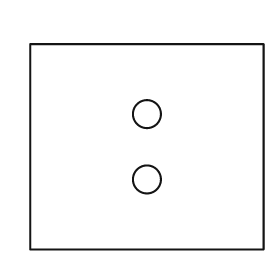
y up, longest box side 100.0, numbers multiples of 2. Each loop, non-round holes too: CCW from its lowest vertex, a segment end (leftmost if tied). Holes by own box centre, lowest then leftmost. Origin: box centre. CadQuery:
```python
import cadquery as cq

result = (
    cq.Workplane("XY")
    .moveTo(-50.0, -44.0)
    .lineTo(50.0, -44.0)
    .lineTo(50.0, 44.0)
    .lineTo(-50.0, 44.0)
    .close()
    .moveTo(0.0, -14.0)
    .circle(6.0)
    .moveTo(0.0, 14.0)
    .circle(6.0)
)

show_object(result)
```